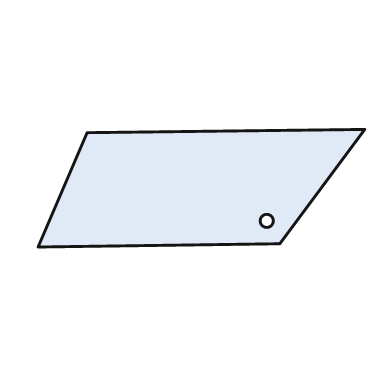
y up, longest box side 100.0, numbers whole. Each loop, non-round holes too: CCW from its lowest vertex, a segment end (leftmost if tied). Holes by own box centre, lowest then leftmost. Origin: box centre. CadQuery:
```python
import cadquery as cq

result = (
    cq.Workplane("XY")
    .moveTo(-50.0, -18.0)
    .lineTo(24.0, -17.0)
    .lineTo(50.0, 18.0)
    .lineTo(-35.0, 17.0)
    .close()
    .moveTo(20.0, -10.0)
    .circle(2.0)
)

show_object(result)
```